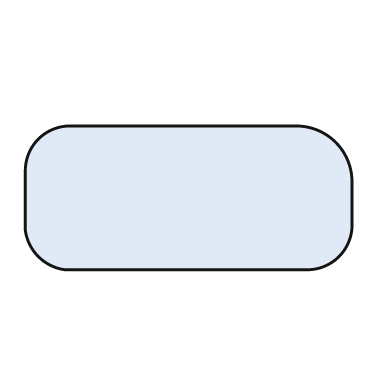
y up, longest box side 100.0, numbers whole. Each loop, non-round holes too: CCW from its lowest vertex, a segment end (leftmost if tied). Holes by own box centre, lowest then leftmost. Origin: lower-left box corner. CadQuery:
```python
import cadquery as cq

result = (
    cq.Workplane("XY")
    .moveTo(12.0, 0.0)
    .lineTo(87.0, 0.0)
    .threePointArc((96.0, 4.0), (100.0, 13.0))
    .lineTo(100.0, 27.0)
    .threePointArc((95.0, 39.0), (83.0, 44.0))
    .lineTo(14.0, 44.0)
    .threePointArc((4.0, 40.0), (0.0, 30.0))
    .lineTo(0.0, 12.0)
    .threePointArc((4.0, 4.0), (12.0, 0.0))
    .close()
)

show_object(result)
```